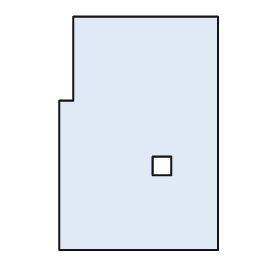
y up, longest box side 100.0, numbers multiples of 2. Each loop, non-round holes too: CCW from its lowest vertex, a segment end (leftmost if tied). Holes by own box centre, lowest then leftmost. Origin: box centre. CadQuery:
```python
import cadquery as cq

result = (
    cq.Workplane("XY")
    .moveTo(-34.0, -50.0)
    .lineTo(34.0, -50.0)
    .lineTo(34.0, 50.0)
    .lineTo(-28.0, 50.0)
    .lineTo(-28.0, 14.0)
    .lineTo(-34.0, 14.0)
    .close()
    .moveTo(6.0, -18.0)
    .lineTo(14.0, -18.0)
    .lineTo(14.0, -10.0)
    .lineTo(6.0, -10.0)
    .close()
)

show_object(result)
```